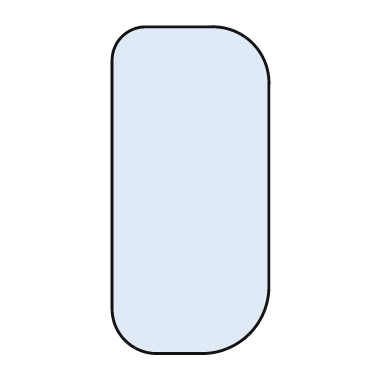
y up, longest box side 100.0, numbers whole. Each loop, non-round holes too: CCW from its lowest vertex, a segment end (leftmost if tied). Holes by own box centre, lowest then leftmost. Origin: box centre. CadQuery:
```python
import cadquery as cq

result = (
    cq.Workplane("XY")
    .moveTo(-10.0, -50.0)
    .lineTo(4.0, -50.0)
    .threePointArc((18.0, -44.0), (24.0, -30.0))
    .lineTo(24.0, 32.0)
    .threePointArc((19.0, 45.0), (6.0, 50.0))
    .lineTo(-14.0, 50.0)
    .threePointArc((-21.0, 47.0), (-24.0, 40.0))
    .lineTo(-24.0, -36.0)
    .threePointArc((-20.0, -46.0), (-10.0, -50.0))
    .close()
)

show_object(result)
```